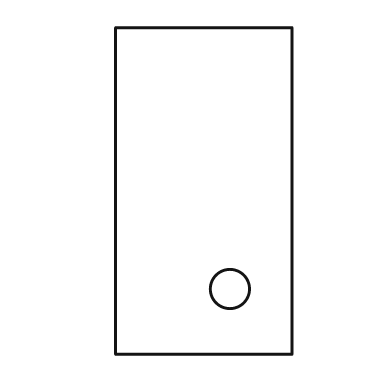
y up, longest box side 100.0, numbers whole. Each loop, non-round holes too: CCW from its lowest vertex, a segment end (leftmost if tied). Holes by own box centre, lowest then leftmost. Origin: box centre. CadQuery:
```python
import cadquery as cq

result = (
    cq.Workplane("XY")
    .moveTo(-27.0, -50.0)
    .lineTo(27.0, -50.0)
    .lineTo(27.0, 50.0)
    .lineTo(-27.0, 50.0)
    .close()
    .moveTo(8.0, -30.0)
    .circle(6.0)
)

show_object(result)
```